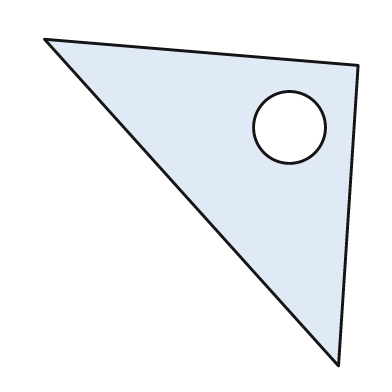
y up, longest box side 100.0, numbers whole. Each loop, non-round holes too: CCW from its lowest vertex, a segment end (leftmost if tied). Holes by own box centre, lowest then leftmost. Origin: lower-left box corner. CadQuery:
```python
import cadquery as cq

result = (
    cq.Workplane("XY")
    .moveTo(90.0, 0.0)
    .lineTo(96.0, 92.0)
    .lineTo(0.0, 100.0)
    .close()
    .moveTo(75.0, 73.0)
    .circle(11.0)
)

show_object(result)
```